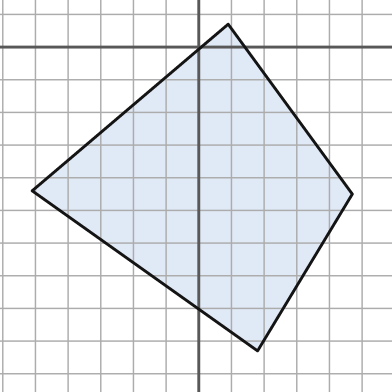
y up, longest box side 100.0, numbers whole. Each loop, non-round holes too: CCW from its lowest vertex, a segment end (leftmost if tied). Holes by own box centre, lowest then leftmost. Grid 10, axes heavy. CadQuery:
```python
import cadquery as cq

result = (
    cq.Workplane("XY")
    .moveTo(18.0, -93.0)
    .lineTo(47.0, -45.0)
    .lineTo(9.0, 7.0)
    .lineTo(-51.0, -44.0)
    .close()
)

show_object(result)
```